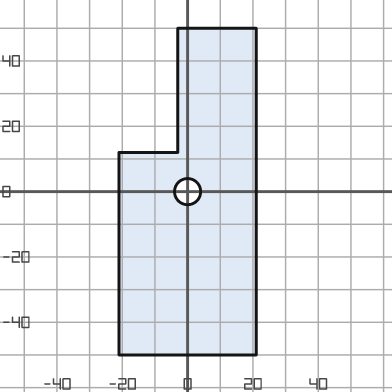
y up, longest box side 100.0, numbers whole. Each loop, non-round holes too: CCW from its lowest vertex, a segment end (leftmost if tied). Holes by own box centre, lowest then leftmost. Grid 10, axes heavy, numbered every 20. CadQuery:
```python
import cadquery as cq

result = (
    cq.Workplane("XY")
    .moveTo(-21.0, -50.0)
    .lineTo(21.0, -50.0)
    .lineTo(21.0, 50.0)
    .lineTo(-3.0, 50.0)
    .lineTo(-3.0, 12.0)
    .lineTo(-21.0, 12.0)
    .close()
    .moveTo(0.0, 0.0)
    .circle(4.0)
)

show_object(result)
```